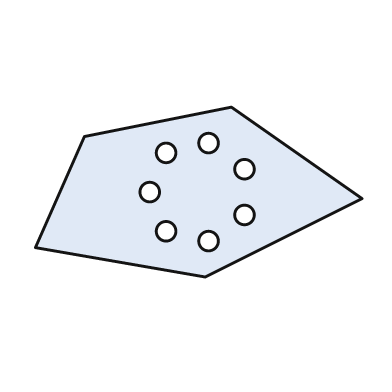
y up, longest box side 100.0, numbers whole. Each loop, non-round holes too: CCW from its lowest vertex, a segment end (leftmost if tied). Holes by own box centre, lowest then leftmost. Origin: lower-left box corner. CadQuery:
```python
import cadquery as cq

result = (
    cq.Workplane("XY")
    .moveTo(52.0, 0.0)
    .lineTo(100.0, 24.0)
    .lineTo(60.0, 52.0)
    .lineTo(15.0, 43.0)
    .lineTo(0.0, 9.0)
    .close()
    .moveTo(53.0, 11.0)
    .circle(3.0)
    .moveTo(40.0, 14.0)
    .circle(3.0)
    .moveTo(64.0, 19.0)
    .circle(3.0)
    .moveTo(35.0, 26.0)
    .circle(3.0)
    .moveTo(64.0, 33.0)
    .circle(3.0)
    .moveTo(40.0, 38.0)
    .circle(3.0)
    .moveTo(53.0, 41.0)
    .circle(3.0)
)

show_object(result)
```